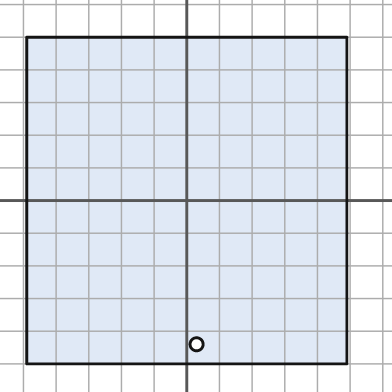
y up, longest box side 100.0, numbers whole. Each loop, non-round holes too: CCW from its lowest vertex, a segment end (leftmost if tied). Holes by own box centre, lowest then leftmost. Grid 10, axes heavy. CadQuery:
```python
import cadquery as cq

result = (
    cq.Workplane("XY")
    .moveTo(-49.0, -50.0)
    .lineTo(49.0, -50.0)
    .lineTo(49.0, 50.0)
    .lineTo(-49.0, 50.0)
    .close()
    .moveTo(3.0, -44.0)
    .circle(2.0)
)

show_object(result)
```